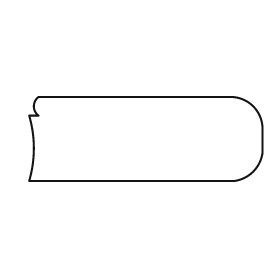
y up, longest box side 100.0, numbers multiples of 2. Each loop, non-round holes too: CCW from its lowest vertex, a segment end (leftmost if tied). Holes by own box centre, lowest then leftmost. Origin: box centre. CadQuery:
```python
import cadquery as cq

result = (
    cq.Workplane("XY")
    .moveTo(-50.0, -18.0)
    .lineTo(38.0, -18.0)
    .threePointArc((46.0, -14.0), (50.0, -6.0))
    .lineTo(50.0, 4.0)
    .threePointArc((46.0, 14.0), (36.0, 18.0))
    .lineTo(-46.0, 18.0)
    .threePointArc((-48.0, 14.0), (-46.0, 10.0))
    .lineTo(-50.0, 10.0)
    .threePointArc((-48.0, -4.0), (-50.0, -18.0))
    .close()
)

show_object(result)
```